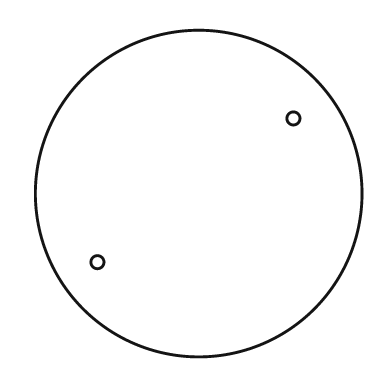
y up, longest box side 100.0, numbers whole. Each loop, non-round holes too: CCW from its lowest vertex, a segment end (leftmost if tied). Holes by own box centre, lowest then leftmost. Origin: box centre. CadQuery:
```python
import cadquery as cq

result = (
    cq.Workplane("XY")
    .moveTo(0.0, 0.0)
    .circle(50.0)
    .moveTo(-31.0, -21.0)
    .circle(2.0)
    .moveTo(29.0, 23.0)
    .circle(2.0)
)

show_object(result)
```